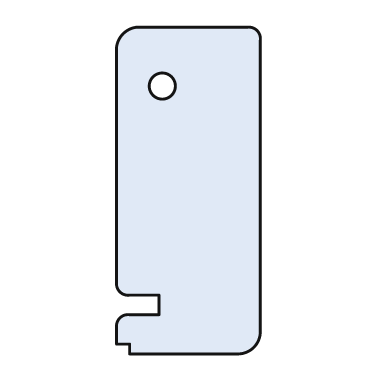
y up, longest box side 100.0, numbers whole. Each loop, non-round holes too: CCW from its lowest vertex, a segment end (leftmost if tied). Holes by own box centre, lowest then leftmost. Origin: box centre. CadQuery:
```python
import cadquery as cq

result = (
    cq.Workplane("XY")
    .moveTo(-18.0, -50.0)
    .lineTo(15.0, -50.0)
    .threePointArc((20.0, -48.0), (22.0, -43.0))
    .lineTo(22.0, 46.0)
    .threePointArc((21.0, 49.0), (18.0, 50.0))
    .lineTo(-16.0, 50.0)
    .threePointArc((-20.0, 48.0), (-22.0, 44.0))
    .lineTo(-22.0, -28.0)
    .threePointArc((-21.0, -31.0), (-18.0, -32.0))
    .lineTo(-9.0, -32.0)
    .lineTo(-9.0, -38.0)
    .lineTo(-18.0, -38.0)
    .threePointArc((-21.0, -39.0), (-22.0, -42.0))
    .lineTo(-22.0, -47.0)
    .lineTo(-18.0, -47.0)
    .close()
    .moveTo(-8.0, 32.0)
    .circle(4.0)
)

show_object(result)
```